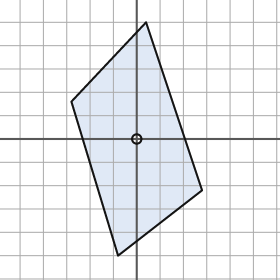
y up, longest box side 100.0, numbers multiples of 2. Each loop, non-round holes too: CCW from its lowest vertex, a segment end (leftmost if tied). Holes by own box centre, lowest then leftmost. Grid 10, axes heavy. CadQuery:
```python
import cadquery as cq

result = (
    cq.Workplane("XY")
    .moveTo(-8.0, -50.0)
    .lineTo(28.0, -22.0)
    .lineTo(4.0, 50.0)
    .lineTo(-28.0, 16.0)
    .close()
    .moveTo(0.0, 0.0)
    .circle(2.0)
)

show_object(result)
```